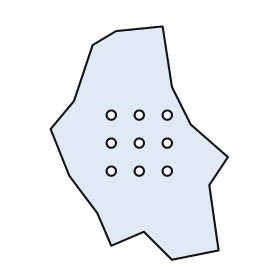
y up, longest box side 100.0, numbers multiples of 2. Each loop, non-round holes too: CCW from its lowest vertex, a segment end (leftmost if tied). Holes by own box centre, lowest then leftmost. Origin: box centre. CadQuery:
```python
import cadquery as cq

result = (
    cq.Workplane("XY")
    .moveTo(14.0, -50.0)
    .lineTo(34.0, -46.0)
    .lineTo(30.0, -18.0)
    .lineTo(38.0, -6.0)
    .lineTo(22.0, 8.0)
    .lineTo(14.0, 24.0)
    .lineTo(10.0, 50.0)
    .lineTo(-10.0, 48.0)
    .lineTo(-20.0, 42.0)
    .lineTo(-28.0, 18.0)
    .lineTo(-38.0, 6.0)
    .lineTo(-30.0, -14.0)
    .lineTo(-18.0, -30.0)
    .lineTo(-12.0, -44.0)
    .lineTo(2.0, -38.0)
    .close()
    .moveTo(-12.0, -12.0)
    .circle(2.0)
    .moveTo(0.0, -12.0)
    .circle(2.0)
    .moveTo(12.0, -12.0)
    .circle(2.0)
    .moveTo(-12.0, 0.0)
    .circle(2.0)
    .moveTo(0.0, 0.0)
    .circle(2.0)
    .moveTo(12.0, 0.0)
    .circle(2.0)
    .moveTo(-12.0, 12.0)
    .circle(2.0)
    .moveTo(0.0, 12.0)
    .circle(2.0)
    .moveTo(12.0, 12.0)
    .circle(2.0)
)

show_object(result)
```